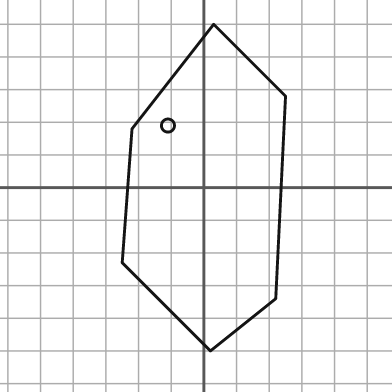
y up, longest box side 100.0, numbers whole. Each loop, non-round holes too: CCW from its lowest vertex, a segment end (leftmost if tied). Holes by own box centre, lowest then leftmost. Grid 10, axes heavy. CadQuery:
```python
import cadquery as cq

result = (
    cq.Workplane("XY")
    .moveTo(2.0, -50.0)
    .lineTo(22.0, -34.0)
    .lineTo(25.0, 28.0)
    .lineTo(3.0, 50.0)
    .lineTo(-22.0, 18.0)
    .lineTo(-25.0, -23.0)
    .close()
    .moveTo(-11.0, 19.0)
    .circle(2.0)
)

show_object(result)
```